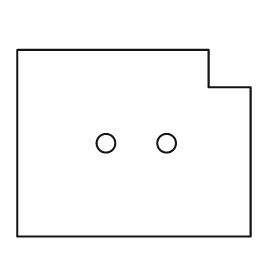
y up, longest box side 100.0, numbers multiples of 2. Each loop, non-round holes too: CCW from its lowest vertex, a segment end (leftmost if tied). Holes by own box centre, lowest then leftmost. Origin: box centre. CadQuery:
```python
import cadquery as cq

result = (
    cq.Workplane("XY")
    .moveTo(-50.0, -40.0)
    .lineTo(50.0, -40.0)
    .lineTo(50.0, 24.0)
    .lineTo(32.0, 24.0)
    .lineTo(32.0, 40.0)
    .lineTo(-50.0, 40.0)
    .close()
    .moveTo(-12.0, 0.0)
    .circle(4.0)
    .moveTo(14.0, 0.0)
    .circle(4.0)
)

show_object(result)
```